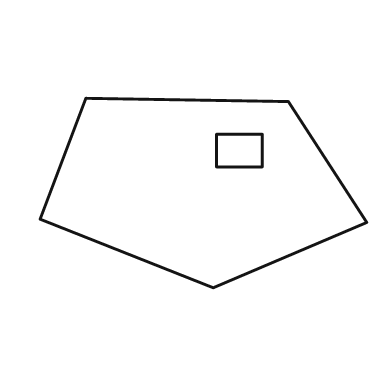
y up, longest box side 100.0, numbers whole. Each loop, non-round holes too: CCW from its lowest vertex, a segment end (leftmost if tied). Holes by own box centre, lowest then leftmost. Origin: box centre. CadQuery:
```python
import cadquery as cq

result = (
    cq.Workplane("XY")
    .moveTo(3.0, -29.0)
    .lineTo(50.0, -9.0)
    .lineTo(26.0, 28.0)
    .lineTo(-36.0, 29.0)
    .lineTo(-50.0, -8.0)
    .close()
    .moveTo(4.0, 8.0)
    .lineTo(18.0, 8.0)
    .lineTo(18.0, 18.0)
    .lineTo(4.0, 18.0)
    .close()
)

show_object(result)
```